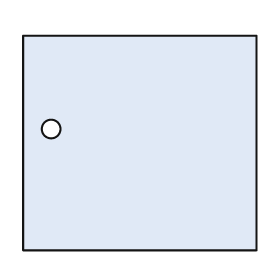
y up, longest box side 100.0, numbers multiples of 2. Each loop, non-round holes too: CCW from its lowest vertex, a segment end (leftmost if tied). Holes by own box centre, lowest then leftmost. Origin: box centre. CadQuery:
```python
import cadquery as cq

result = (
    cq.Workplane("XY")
    .moveTo(-50.0, -46.0)
    .lineTo(50.0, -46.0)
    .lineTo(50.0, 46.0)
    .lineTo(-50.0, 46.0)
    .close()
    .moveTo(-38.0, 6.0)
    .circle(4.0)
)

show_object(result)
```